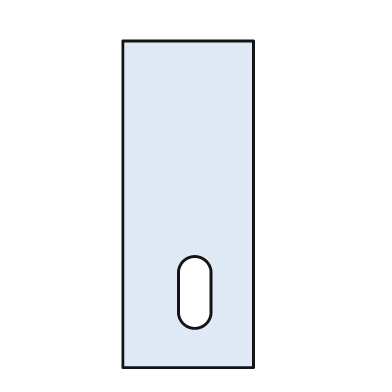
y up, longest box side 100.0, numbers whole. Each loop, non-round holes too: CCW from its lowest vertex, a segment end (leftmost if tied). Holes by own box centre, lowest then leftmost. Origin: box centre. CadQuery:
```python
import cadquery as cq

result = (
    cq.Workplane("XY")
    .moveTo(-20.0, -50.0)
    .lineTo(20.0, -50.0)
    .lineTo(20.0, 50.0)
    .lineTo(-20.0, 50.0)
    .close()
    .moveTo(-3.0, -33.0)
    .threePointArc((2.0, -38.0), (7.0, -33.0))
    .lineTo(7.0, -21.0)
    .threePointArc((2.0, -16.0), (-3.0, -21.0))
    .close()
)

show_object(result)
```